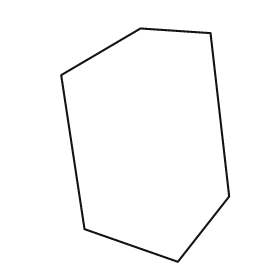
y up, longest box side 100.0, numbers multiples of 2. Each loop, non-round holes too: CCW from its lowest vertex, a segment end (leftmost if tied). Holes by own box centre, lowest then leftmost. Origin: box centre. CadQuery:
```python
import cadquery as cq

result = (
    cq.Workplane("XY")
    .moveTo(14.0, -50.0)
    .lineTo(36.0, -22.0)
    .lineTo(28.0, 48.0)
    .lineTo(-2.0, 50.0)
    .lineTo(-36.0, 30.0)
    .lineTo(-26.0, -36.0)
    .close()
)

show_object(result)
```